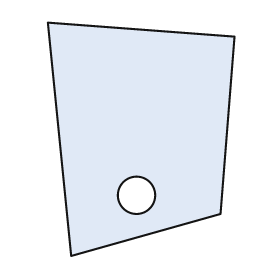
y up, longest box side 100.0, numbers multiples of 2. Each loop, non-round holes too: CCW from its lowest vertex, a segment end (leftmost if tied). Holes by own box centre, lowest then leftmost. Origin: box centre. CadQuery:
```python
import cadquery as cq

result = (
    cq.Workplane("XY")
    .moveTo(-30.0, -50.0)
    .lineTo(34.0, -32.0)
    .lineTo(40.0, 44.0)
    .lineTo(-40.0, 50.0)
    .close()
    .moveTo(-2.0, -24.0)
    .circle(8.0)
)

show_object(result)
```